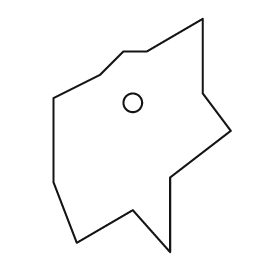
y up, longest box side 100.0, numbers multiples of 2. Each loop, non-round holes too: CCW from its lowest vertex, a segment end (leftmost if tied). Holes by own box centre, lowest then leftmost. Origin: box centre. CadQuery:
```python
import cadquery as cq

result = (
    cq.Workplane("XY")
    .moveTo(12.0, -50.0)
    .lineTo(12.0, -18.0)
    .lineTo(38.0, 2.0)
    .lineTo(26.0, 18.0)
    .lineTo(26.0, 50.0)
    .lineTo(2.0, 36.0)
    .lineTo(-8.0, 36.0)
    .lineTo(-18.0, 26.0)
    .lineTo(-38.0, 16.0)
    .lineTo(-38.0, -20.0)
    .lineTo(-28.0, -46.0)
    .lineTo(-4.0, -32.0)
    .close()
    .moveTo(-4.0, 14.0)
    .circle(4.0)
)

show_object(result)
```